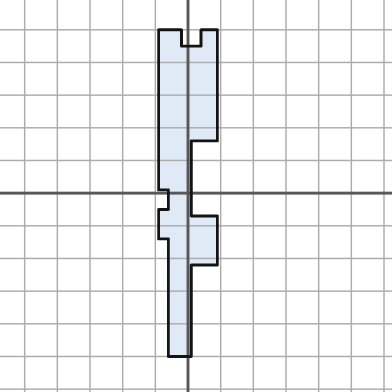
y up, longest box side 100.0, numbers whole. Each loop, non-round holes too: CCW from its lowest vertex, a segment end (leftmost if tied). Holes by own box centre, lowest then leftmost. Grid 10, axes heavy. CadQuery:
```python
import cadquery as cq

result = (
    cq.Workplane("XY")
    .moveTo(-6.0, -50.0)
    .lineTo(1.0, -50.0)
    .lineTo(1.0, -22.0)
    .lineTo(9.0, -22.0)
    .lineTo(9.0, -7.0)
    .lineTo(1.0, -7.0)
    .lineTo(1.0, 16.0)
    .lineTo(9.0, 16.0)
    .lineTo(9.0, 50.0)
    .lineTo(4.0, 50.0)
    .lineTo(4.0, 45.0)
    .lineTo(-2.0, 45.0)
    .lineTo(-2.0, 50.0)
    .lineTo(-9.0, 50.0)
    .lineTo(-9.0, 1.0)
    .lineTo(-6.0, 1.0)
    .lineTo(-6.0, -5.0)
    .lineTo(-9.0, -5.0)
    .lineTo(-9.0, -14.0)
    .lineTo(-6.0, -14.0)
    .close()
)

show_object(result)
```